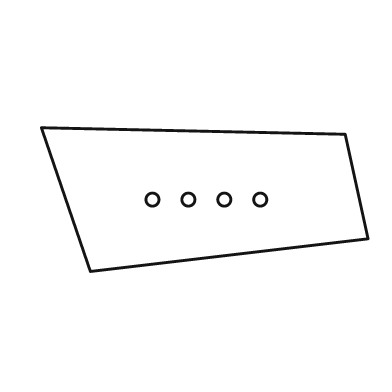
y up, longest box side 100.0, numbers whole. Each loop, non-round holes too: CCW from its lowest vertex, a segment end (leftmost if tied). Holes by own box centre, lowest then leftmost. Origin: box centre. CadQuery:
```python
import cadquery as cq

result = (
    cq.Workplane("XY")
    .moveTo(-35.0, -22.0)
    .lineTo(50.0, -12.0)
    .lineTo(43.0, 20.0)
    .lineTo(-50.0, 22.0)
    .close()
    .moveTo(-16.0, 0.0)
    .circle(2.0)
    .moveTo(-5.0, 0.0)
    .circle(2.0)
    .moveTo(6.0, 0.0)
    .circle(2.0)
    .moveTo(17.0, 0.0)
    .circle(2.0)
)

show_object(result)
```